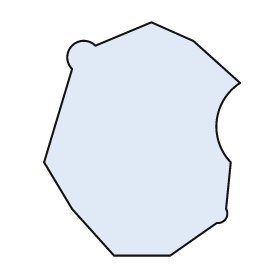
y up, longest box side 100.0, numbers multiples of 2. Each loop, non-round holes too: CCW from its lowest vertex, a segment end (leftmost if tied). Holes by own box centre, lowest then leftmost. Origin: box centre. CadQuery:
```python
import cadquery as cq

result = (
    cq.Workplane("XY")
    .moveTo(-12.0, -50.0)
    .lineTo(12.0, -50.0)
    .lineTo(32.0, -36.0)
    .threePointArc((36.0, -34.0), (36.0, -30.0))
    .lineTo(38.0, -10.0)
    .threePointArc((32.0, 8.0), (42.0, 24.0))
    .lineTo(22.0, 42.0)
    .lineTo(4.0, 50.0)
    .lineTo(-20.0, 40.0)
    .threePointArc((-30.0, 40.0), (-30.0, 30.0))
    .lineTo(-42.0, -10.0)
    .lineTo(-30.0, -30.0)
    .close()
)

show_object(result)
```